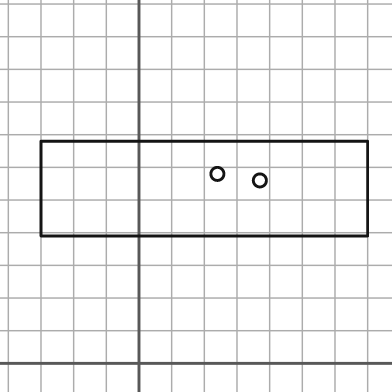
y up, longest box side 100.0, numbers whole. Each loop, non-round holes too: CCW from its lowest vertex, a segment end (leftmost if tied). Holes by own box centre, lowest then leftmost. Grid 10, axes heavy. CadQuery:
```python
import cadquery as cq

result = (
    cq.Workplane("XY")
    .moveTo(-30.0, 39.0)
    .lineTo(70.0, 39.0)
    .lineTo(70.0, 68.0)
    .lineTo(-30.0, 68.0)
    .close()
    .moveTo(37.0, 56.0)
    .circle(2.0)
    .moveTo(24.0, 58.0)
    .circle(2.0)
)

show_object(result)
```